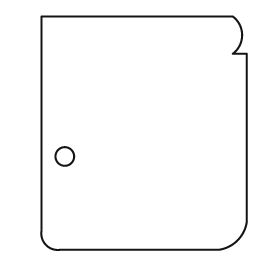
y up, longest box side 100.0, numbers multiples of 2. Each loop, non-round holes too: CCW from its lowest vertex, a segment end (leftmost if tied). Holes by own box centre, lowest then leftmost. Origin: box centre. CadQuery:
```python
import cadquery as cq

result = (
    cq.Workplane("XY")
    .moveTo(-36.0, -50.0)
    .lineTo(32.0, -50.0)
    .threePointArc((40.0, -46.0), (44.0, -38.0))
    .lineTo(44.0, 34.0)
    .lineTo(38.0, 34.0)
    .threePointArc((42.0, 42.0), (38.0, 50.0))
    .lineTo(-44.0, 50.0)
    .lineTo(-44.0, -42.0)
    .threePointArc((-42.0, -48.0), (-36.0, -50.0))
    .close()
    .moveTo(-34.0, -10.0)
    .circle(4.0)
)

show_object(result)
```